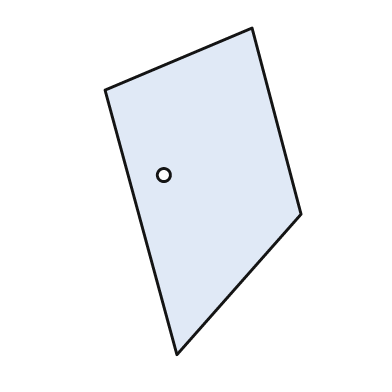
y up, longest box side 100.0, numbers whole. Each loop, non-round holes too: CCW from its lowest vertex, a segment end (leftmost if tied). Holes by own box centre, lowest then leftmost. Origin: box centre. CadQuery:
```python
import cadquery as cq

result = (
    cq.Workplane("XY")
    .moveTo(-8.0, -50.0)
    .lineTo(30.0, -7.0)
    .lineTo(15.0, 50.0)
    .lineTo(-30.0, 31.0)
    .close()
    .moveTo(-12.0, 5.0)
    .circle(2.0)
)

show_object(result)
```